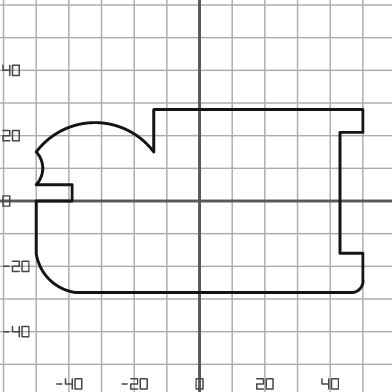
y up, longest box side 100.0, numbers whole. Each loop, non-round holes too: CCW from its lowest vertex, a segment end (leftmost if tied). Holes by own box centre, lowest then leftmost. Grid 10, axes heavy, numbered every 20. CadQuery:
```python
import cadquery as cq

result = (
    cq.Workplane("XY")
    .moveTo(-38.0, -28.0)
    .lineTo(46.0, -28.0)
    .threePointArc((49.0, -27.0), (50.0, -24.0))
    .lineTo(50.0, -16.0)
    .lineTo(43.0, -16.0)
    .lineTo(43.0, 21.0)
    .lineTo(50.0, 21.0)
    .lineTo(50.0, 28.0)
    .lineTo(-14.0, 28.0)
    .lineTo(-14.0, 15.0)
    .threePointArc((-32.0, 24.0), (-50.0, 15.0))
    .threePointArc((-48.0, 10.0), (-50.0, 5.0))
    .lineTo(-39.0, 5.0)
    .lineTo(-39.0, 0.0)
    .lineTo(-50.0, 0.0)
    .lineTo(-50.0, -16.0)
    .threePointArc((-46.0, -24.0), (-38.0, -28.0))
    .close()
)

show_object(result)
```